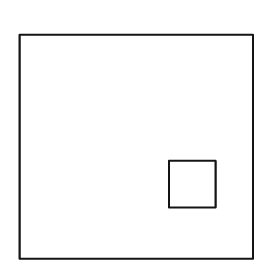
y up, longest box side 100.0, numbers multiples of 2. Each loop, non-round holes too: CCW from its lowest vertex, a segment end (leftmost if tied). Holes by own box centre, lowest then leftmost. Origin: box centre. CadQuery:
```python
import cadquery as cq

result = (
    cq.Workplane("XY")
    .moveTo(-50.0, -48.0)
    .lineTo(50.0, -48.0)
    .lineTo(50.0, 48.0)
    .lineTo(-50.0, 48.0)
    .close()
    .moveTo(14.0, -26.0)
    .lineTo(34.0, -26.0)
    .lineTo(34.0, -6.0)
    .lineTo(14.0, -6.0)
    .close()
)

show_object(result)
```